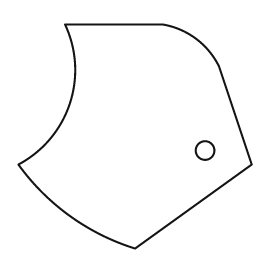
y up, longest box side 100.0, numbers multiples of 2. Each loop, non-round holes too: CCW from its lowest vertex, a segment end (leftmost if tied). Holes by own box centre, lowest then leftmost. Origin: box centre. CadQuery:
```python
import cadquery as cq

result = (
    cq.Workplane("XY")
    .moveTo(0.0, -48.0)
    .lineTo(50.0, -12.0)
    .lineTo(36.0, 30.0)
    .threePointArc((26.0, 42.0), (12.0, 48.0))
    .lineTo(-30.0, 48.0)
    .threePointArc((-28.0, 14.0), (-50.0, -12.0))
    .threePointArc((-28.0, -34.0), (0.0, -48.0))
    .close()
    .moveTo(30.0, -6.0)
    .circle(4.0)
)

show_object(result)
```